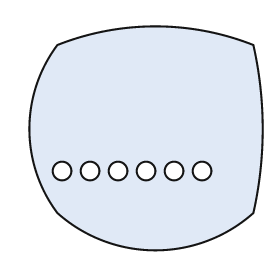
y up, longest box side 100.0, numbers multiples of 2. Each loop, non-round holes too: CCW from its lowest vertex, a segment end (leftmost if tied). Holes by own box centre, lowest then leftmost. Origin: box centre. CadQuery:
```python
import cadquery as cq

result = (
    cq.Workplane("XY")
    .moveTo(-38.0, -32.0)
    .threePointArc((4.0, -48.0), (46.0, -32.0))
    .threePointArc((50.0, 4.0), (46.0, 40.0))
    .threePointArc((4.0, 48.0), (-38.0, 40.0))
    .threePointArc((-50.0, 4.0), (-38.0, -32.0))
    .close()
    .moveTo(-36.0, -14.0)
    .circle(4.0)
    .moveTo(-24.0, -14.0)
    .circle(4.0)
    .moveTo(-12.0, -14.0)
    .circle(4.0)
    .moveTo(0.0, -14.0)
    .circle(4.0)
    .moveTo(12.0, -14.0)
    .circle(4.0)
    .moveTo(24.0, -14.0)
    .circle(4.0)
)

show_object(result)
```